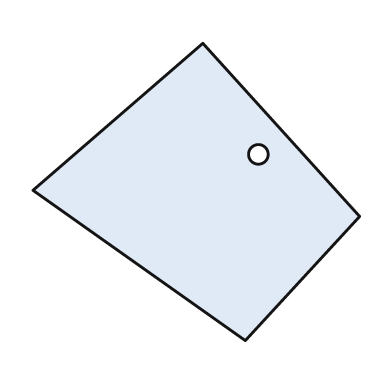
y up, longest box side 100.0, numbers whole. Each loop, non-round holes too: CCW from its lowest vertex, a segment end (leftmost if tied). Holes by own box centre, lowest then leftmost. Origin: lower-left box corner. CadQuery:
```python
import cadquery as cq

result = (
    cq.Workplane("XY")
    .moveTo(65.0, 0.0)
    .lineTo(100.0, 38.0)
    .lineTo(52.0, 91.0)
    .lineTo(0.0, 46.0)
    .close()
    .moveTo(69.0, 57.0)
    .circle(3.0)
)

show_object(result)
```